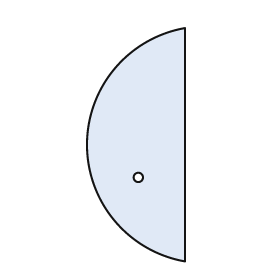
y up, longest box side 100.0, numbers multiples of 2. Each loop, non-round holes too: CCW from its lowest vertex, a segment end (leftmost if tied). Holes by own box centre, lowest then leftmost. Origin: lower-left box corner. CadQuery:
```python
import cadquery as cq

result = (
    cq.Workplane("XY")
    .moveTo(42.0, 0.0)
    .lineTo(42.0, 100.0)
    .threePointArc((0.0, 50.0), (42.0, 0.0))
    .close()
    .moveTo(22.0, 36.0)
    .circle(2.0)
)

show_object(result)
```